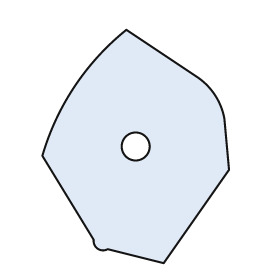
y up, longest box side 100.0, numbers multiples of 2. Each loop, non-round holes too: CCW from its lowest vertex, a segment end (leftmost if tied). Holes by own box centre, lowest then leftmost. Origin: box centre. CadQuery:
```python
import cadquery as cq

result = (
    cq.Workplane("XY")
    .moveTo(12.0, -50.0)
    .lineTo(40.0, -10.0)
    .lineTo(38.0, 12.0)
    .threePointArc((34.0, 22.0), (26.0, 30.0))
    .lineTo(-4.0, 50.0)
    .threePointArc((-26.0, 26.0), (-40.0, -4.0))
    .lineTo(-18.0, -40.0)
    .threePointArc((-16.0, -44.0), (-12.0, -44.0))
    .close()
    .moveTo(0.0, 0.0)
    .circle(6.0)
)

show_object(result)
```